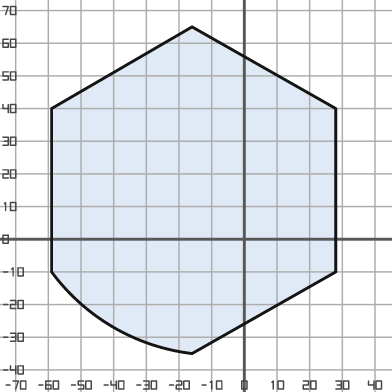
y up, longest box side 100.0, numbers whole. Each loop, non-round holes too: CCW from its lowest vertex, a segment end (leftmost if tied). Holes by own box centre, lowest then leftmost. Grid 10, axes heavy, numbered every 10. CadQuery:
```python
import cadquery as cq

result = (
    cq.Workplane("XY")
    .moveTo(-16.0, -35.0)
    .lineTo(28.0, -10.0)
    .lineTo(28.0, 40.0)
    .lineTo(-16.0, 65.0)
    .lineTo(-59.0, 40.0)
    .lineTo(-59.0, -10.0)
    .threePointArc((-40.0, -27.0), (-16.0, -35.0))
    .close()
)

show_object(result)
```